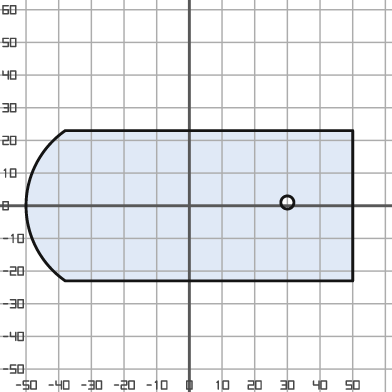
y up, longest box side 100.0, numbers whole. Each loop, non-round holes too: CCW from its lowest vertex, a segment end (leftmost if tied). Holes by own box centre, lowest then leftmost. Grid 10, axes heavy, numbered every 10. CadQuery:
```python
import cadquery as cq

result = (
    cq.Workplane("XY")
    .moveTo(-38.0, -23.0)
    .lineTo(50.0, -23.0)
    .lineTo(50.0, 23.0)
    .lineTo(-38.0, 23.0)
    .threePointArc((-50.0, 0.0), (-38.0, -23.0))
    .close()
    .moveTo(30.0, 1.0)
    .circle(2.0)
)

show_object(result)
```